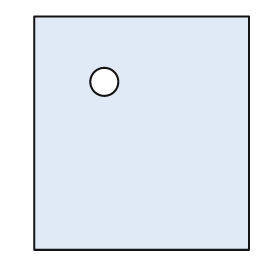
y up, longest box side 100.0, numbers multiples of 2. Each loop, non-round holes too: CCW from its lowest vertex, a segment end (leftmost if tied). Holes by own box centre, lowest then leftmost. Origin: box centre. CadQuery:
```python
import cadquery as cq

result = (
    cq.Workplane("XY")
    .moveTo(-46.0, -50.0)
    .lineTo(46.0, -50.0)
    .lineTo(46.0, 50.0)
    .lineTo(-46.0, 50.0)
    .close()
    .moveTo(-16.0, 22.0)
    .circle(6.0)
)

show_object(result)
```